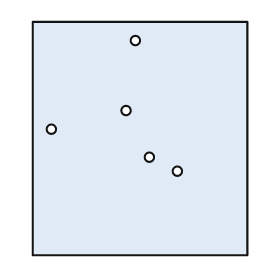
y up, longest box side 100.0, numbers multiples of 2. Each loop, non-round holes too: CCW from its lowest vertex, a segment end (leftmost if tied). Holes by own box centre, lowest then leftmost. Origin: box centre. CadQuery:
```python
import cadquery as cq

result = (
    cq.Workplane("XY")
    .moveTo(-46.0, -50.0)
    .lineTo(46.0, -50.0)
    .lineTo(46.0, 50.0)
    .lineTo(-46.0, 50.0)
    .close()
    .moveTo(16.0, -14.0)
    .circle(2.0)
    .moveTo(4.0, -8.0)
    .circle(2.0)
    .moveTo(-38.0, 4.0)
    .circle(2.0)
    .moveTo(-6.0, 12.0)
    .circle(2.0)
    .moveTo(-2.0, 42.0)
    .circle(2.0)
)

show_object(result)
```